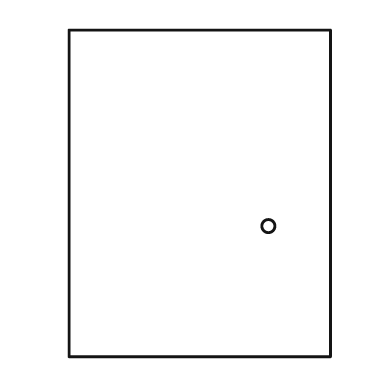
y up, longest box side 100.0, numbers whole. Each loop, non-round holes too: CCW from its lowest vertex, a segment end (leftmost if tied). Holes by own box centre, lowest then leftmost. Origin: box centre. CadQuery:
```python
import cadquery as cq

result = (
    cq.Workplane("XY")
    .moveTo(-40.0, -50.0)
    .lineTo(40.0, -50.0)
    .lineTo(40.0, 50.0)
    .lineTo(-40.0, 50.0)
    .close()
    .moveTo(21.0, -10.0)
    .circle(2.0)
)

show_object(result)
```